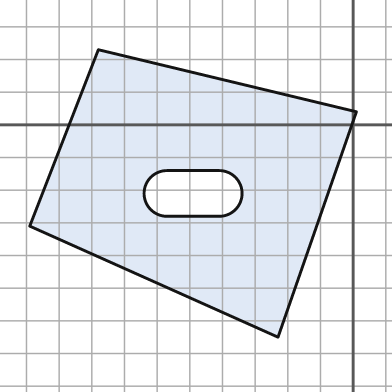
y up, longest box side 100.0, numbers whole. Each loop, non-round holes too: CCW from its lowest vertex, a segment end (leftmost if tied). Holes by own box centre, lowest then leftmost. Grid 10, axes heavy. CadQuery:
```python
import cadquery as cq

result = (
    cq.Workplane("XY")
    .moveTo(-23.0, -65.0)
    .lineTo(1.0, 4.0)
    .lineTo(-78.0, 23.0)
    .lineTo(-99.0, -31.0)
    .close()
    .moveTo(-57.0, -28.0)
    .lineTo(-41.0, -28.0)
    .threePointArc((-34.0, -21.0), (-41.0, -14.0))
    .lineTo(-57.0, -14.0)
    .threePointArc((-64.0, -21.0), (-57.0, -28.0))
    .close()
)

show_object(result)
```